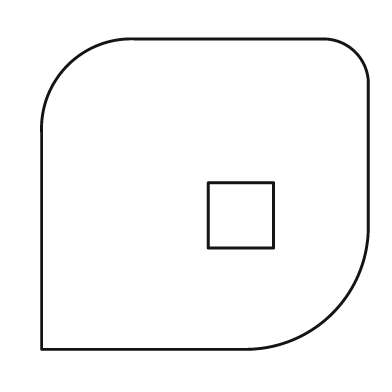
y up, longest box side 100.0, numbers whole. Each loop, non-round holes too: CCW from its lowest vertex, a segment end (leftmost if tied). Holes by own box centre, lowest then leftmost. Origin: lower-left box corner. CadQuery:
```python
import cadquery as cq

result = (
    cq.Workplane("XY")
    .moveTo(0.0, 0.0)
    .lineTo(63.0, 0.0)
    .threePointArc((89.0, 11.0), (100.0, 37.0))
    .lineTo(100.0, 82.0)
    .threePointArc((96.0, 91.0), (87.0, 95.0))
    .lineTo(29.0, 95.0)
    .threePointArc((8.0, 87.0), (0.0, 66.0))
    .close()
    .moveTo(51.0, 31.0)
    .lineTo(71.0, 31.0)
    .lineTo(71.0, 51.0)
    .lineTo(51.0, 51.0)
    .close()
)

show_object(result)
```